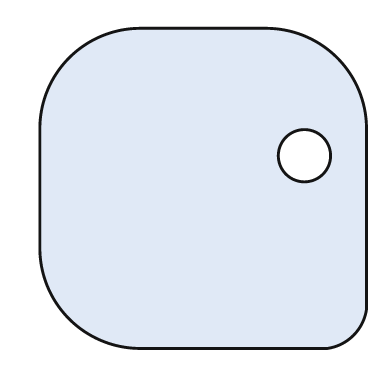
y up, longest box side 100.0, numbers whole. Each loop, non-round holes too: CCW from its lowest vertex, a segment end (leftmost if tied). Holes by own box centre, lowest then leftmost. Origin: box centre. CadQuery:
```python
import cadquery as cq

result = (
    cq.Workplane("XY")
    .moveTo(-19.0, -49.0)
    .lineTo(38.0, -49.0)
    .threePointArc((46.0, -45.0), (50.0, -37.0))
    .lineTo(50.0, 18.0)
    .threePointArc((41.0, 40.0), (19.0, 49.0))
    .lineTo(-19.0, 49.0)
    .threePointArc((-41.0, 40.0), (-50.0, 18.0))
    .lineTo(-50.0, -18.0)
    .threePointArc((-41.0, -40.0), (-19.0, -49.0))
    .close()
    .moveTo(31.0, 10.0)
    .circle(8.0)
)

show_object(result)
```